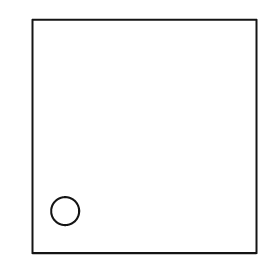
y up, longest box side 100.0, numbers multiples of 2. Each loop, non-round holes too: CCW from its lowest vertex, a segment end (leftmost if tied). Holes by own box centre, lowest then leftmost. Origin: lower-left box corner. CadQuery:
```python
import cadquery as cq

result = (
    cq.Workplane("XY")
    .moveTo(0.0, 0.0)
    .lineTo(96.0, 0.0)
    .lineTo(96.0, 100.0)
    .lineTo(0.0, 100.0)
    .close()
    .moveTo(14.0, 18.0)
    .circle(6.0)
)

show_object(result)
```